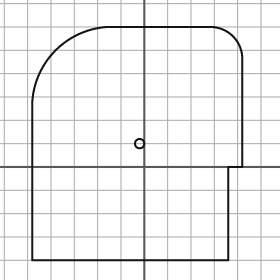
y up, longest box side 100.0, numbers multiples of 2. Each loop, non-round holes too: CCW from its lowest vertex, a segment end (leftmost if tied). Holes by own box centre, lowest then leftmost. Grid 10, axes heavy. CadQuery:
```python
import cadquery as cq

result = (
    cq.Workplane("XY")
    .moveTo(-48.0, -40.0)
    .lineTo(36.0, -40.0)
    .lineTo(36.0, 0.0)
    .lineTo(42.0, 0.0)
    .lineTo(42.0, 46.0)
    .threePointArc((38.0, 56.0), (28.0, 60.0))
    .lineTo(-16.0, 60.0)
    .threePointArc((-38.0, 50.0), (-48.0, 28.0))
    .close()
    .moveTo(-2.0, 10.0)
    .circle(2.0)
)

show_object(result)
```